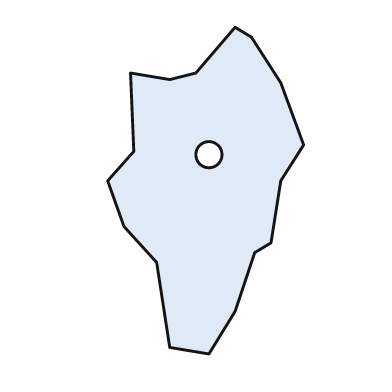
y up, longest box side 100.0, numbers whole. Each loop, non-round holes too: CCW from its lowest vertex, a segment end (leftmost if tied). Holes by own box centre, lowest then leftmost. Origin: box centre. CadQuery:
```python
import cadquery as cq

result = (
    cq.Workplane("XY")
    .moveTo(1.0, -50.0)
    .lineTo(9.0, -37.0)
    .lineTo(15.0, -19.0)
    .lineTo(20.0, -16.0)
    .lineTo(23.0, 3.0)
    .lineTo(30.0, 14.0)
    .lineTo(23.0, 33.0)
    .lineTo(14.0, 47.0)
    .lineTo(9.0, 50.0)
    .lineTo(-3.0, 36.0)
    .lineTo(-11.0, 34.0)
    .lineTo(-23.0, 36.0)
    .lineTo(-22.0, 12.0)
    .lineTo(-30.0, 3.0)
    .lineTo(-25.0, -11.0)
    .lineTo(-15.0, -22.0)
    .lineTo(-11.0, -48.0)
    .close()
    .moveTo(1.0, 11.0)
    .circle(4.0)
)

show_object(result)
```